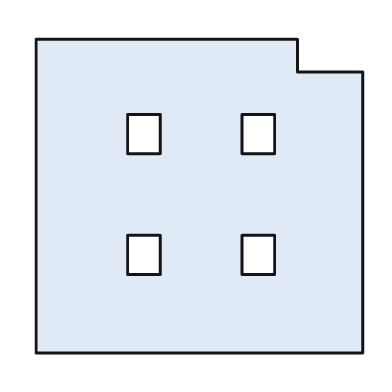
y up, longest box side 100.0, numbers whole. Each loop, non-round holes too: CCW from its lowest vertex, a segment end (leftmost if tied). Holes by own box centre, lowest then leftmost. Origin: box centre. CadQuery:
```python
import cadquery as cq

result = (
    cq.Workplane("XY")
    .moveTo(-50.0, -48.0)
    .lineTo(50.0, -48.0)
    .lineTo(50.0, 38.0)
    .lineTo(30.0, 38.0)
    .lineTo(30.0, 48.0)
    .lineTo(-50.0, 48.0)
    .close()
    .moveTo(-22.0, -24.0)
    .lineTo(-12.0, -24.0)
    .lineTo(-12.0, -12.0)
    .lineTo(-22.0, -12.0)
    .close()
    .moveTo(13.0, -24.0)
    .lineTo(23.0, -24.0)
    .lineTo(23.0, -12.0)
    .lineTo(13.0, -12.0)
    .close()
    .moveTo(-22.0, 13.0)
    .lineTo(-12.0, 13.0)
    .lineTo(-12.0, 25.0)
    .lineTo(-22.0, 25.0)
    .close()
    .moveTo(13.0, 13.0)
    .lineTo(23.0, 13.0)
    .lineTo(23.0, 25.0)
    .lineTo(13.0, 25.0)
    .close()
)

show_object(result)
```